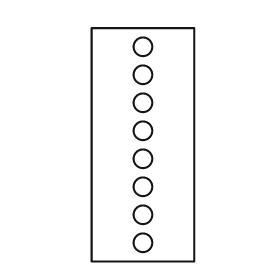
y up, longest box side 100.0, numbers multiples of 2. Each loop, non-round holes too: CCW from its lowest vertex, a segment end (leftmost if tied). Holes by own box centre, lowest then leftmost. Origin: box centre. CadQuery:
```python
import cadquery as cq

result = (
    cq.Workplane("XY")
    .moveTo(-22.0, -50.0)
    .lineTo(22.0, -50.0)
    .lineTo(22.0, 50.0)
    .lineTo(-22.0, 50.0)
    .close()
    .moveTo(0.0, -42.0)
    .circle(4.0)
    .moveTo(0.0, -30.0)
    .circle(4.0)
    .moveTo(0.0, -18.0)
    .circle(4.0)
    .moveTo(0.0, -6.0)
    .circle(4.0)
    .moveTo(0.0, 6.0)
    .circle(4.0)
    .moveTo(0.0, 18.0)
    .circle(4.0)
    .moveTo(0.0, 30.0)
    .circle(4.0)
    .moveTo(0.0, 42.0)
    .circle(4.0)
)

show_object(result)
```